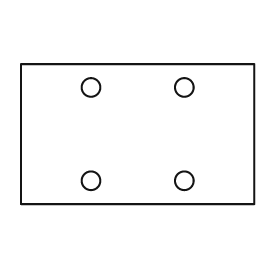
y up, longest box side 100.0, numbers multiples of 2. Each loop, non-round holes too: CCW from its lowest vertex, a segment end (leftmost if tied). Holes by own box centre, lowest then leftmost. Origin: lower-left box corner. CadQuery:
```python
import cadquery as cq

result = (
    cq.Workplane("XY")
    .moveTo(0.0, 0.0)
    .lineTo(100.0, 0.0)
    .lineTo(100.0, 60.0)
    .lineTo(0.0, 60.0)
    .close()
    .moveTo(30.0, 10.0)
    .circle(4.0)
    .moveTo(70.0, 10.0)
    .circle(4.0)
    .moveTo(30.0, 50.0)
    .circle(4.0)
    .moveTo(70.0, 50.0)
    .circle(4.0)
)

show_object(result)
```